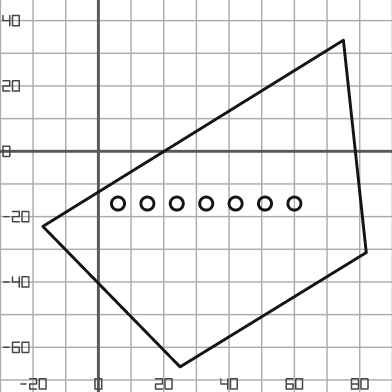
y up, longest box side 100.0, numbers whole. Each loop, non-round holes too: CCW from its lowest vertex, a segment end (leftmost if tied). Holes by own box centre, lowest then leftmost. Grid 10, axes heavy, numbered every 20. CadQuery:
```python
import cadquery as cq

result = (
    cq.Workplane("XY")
    .moveTo(25.0, -66.0)
    .lineTo(82.0, -31.0)
    .lineTo(75.0, 34.0)
    .lineTo(-17.0, -23.0)
    .close()
    .moveTo(6.0, -16.0)
    .circle(2.0)
    .moveTo(15.0, -16.0)
    .circle(2.0)
    .moveTo(24.0, -16.0)
    .circle(2.0)
    .moveTo(33.0, -16.0)
    .circle(2.0)
    .moveTo(42.0, -16.0)
    .circle(2.0)
    .moveTo(51.0, -16.0)
    .circle(2.0)
    .moveTo(60.0, -16.0)
    .circle(2.0)
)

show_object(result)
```